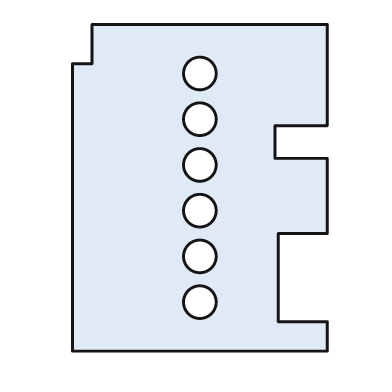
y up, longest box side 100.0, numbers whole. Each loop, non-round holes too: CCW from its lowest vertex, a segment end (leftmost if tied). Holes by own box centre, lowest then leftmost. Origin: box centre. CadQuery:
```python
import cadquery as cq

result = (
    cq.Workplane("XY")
    .moveTo(-39.0, -50.0)
    .lineTo(39.0, -50.0)
    .lineTo(39.0, -41.0)
    .lineTo(24.0, -41.0)
    .lineTo(24.0, -14.0)
    .lineTo(39.0, -14.0)
    .lineTo(39.0, 9.0)
    .lineTo(23.0, 9.0)
    .lineTo(23.0, 19.0)
    .lineTo(39.0, 19.0)
    .lineTo(39.0, 50.0)
    .lineTo(-33.0, 50.0)
    .lineTo(-33.0, 38.0)
    .lineTo(-39.0, 38.0)
    .close()
    .moveTo(0.0, -35.0)
    .circle(5.0)
    .moveTo(0.0, -21.0)
    .circle(5.0)
    .moveTo(0.0, -7.0)
    .circle(5.0)
    .moveTo(0.0, 7.0)
    .circle(5.0)
    .moveTo(0.0, 21.0)
    .circle(5.0)
    .moveTo(0.0, 35.0)
    .circle(5.0)
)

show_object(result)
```